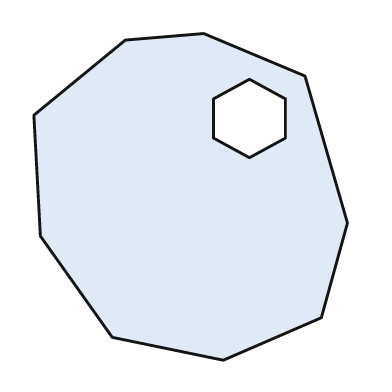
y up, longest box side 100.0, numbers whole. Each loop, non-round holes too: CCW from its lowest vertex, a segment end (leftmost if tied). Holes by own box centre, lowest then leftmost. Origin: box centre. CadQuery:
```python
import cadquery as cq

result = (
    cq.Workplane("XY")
    .moveTo(10.0, -50.0)
    .lineTo(40.0, -37.0)
    .lineTo(48.0, -8.0)
    .lineTo(35.0, 37.0)
    .lineTo(4.0, 50.0)
    .lineTo(-20.0, 48.0)
    .lineTo(-48.0, 25.0)
    .lineTo(-46.0, -12.0)
    .lineTo(-24.0, -43.0)
    .close()
    .moveTo(18.0, 12.0)
    .lineTo(29.0, 18.0)
    .lineTo(29.0, 30.0)
    .lineTo(18.0, 36.0)
    .lineTo(7.0, 30.0)
    .lineTo(7.0, 18.0)
    .close()
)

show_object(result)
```